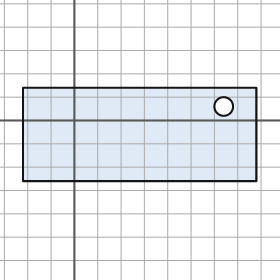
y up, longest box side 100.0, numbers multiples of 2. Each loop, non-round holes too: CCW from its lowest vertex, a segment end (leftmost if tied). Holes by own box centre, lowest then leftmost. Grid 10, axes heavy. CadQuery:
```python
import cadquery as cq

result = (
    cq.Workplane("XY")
    .moveTo(-22.0, -26.0)
    .lineTo(78.0, -26.0)
    .lineTo(78.0, 14.0)
    .lineTo(-22.0, 14.0)
    .close()
    .moveTo(64.0, 6.0)
    .circle(4.0)
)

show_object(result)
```